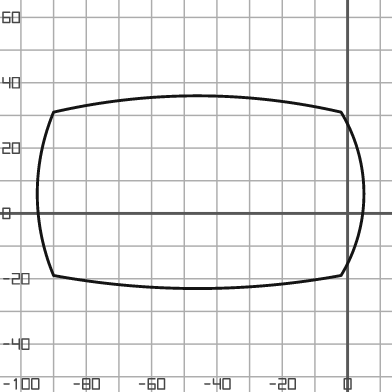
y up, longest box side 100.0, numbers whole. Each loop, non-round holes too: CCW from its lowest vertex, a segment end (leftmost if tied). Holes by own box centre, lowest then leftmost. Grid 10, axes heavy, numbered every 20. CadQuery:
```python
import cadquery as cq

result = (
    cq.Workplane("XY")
    .moveTo(-90.0, -19.0)
    .threePointArc((-46.0, -23.0), (-2.0, -19.0))
    .threePointArc((5.0, 6.0), (-2.0, 31.0))
    .threePointArc((-46.0, 36.0), (-90.0, 31.0))
    .threePointArc((-95.0, 6.0), (-90.0, -19.0))
    .close()
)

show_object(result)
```